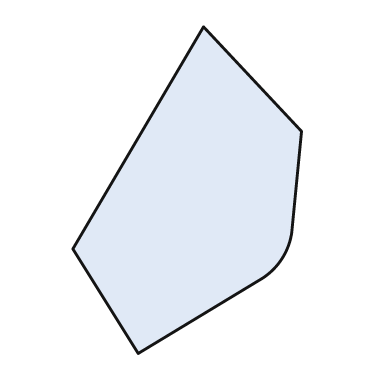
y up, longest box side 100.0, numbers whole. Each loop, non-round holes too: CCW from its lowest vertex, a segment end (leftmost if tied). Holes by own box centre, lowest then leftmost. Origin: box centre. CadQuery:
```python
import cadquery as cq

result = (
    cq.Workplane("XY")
    .moveTo(-15.0, -50.0)
    .lineTo(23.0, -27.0)
    .threePointArc((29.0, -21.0), (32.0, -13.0))
    .lineTo(35.0, 18.0)
    .lineTo(5.0, 50.0)
    .lineTo(-35.0, -18.0)
    .close()
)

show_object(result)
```